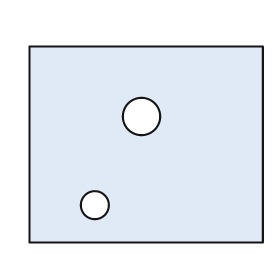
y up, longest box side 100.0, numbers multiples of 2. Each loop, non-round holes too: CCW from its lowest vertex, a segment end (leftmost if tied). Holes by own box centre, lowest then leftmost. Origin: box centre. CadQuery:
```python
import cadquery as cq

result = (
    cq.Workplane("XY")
    .moveTo(-50.0, -42.0)
    .lineTo(50.0, -42.0)
    .lineTo(50.0, 42.0)
    .lineTo(-50.0, 42.0)
    .close()
    .moveTo(-22.0, -26.0)
    .circle(6.0)
    .moveTo(-2.0, 12.0)
    .circle(8.0)
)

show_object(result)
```